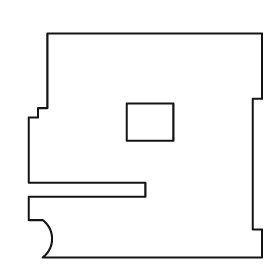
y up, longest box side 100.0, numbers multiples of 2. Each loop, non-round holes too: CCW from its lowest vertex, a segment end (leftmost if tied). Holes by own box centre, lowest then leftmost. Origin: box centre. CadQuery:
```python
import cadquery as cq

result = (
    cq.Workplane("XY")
    .moveTo(-44.0, -48.0)
    .lineTo(50.0, -48.0)
    .lineTo(50.0, -36.0)
    .lineTo(46.0, -36.0)
    .lineTo(46.0, 20.0)
    .lineTo(50.0, 20.0)
    .lineTo(50.0, 48.0)
    .lineTo(-42.0, 48.0)
    .lineTo(-42.0, 16.0)
    .lineTo(-46.0, 16.0)
    .lineTo(-46.0, 12.0)
    .lineTo(-50.0, 12.0)
    .lineTo(-50.0, -16.0)
    .lineTo(0.0, -16.0)
    .lineTo(0.0, -22.0)
    .lineTo(-50.0, -22.0)
    .lineTo(-50.0, -32.0)
    .lineTo(-44.0, -32.0)
    .threePointArc((-40.0, -40.0), (-44.0, -48.0))
    .close()
    .moveTo(-8.0, 2.0)
    .lineTo(12.0, 2.0)
    .lineTo(12.0, 18.0)
    .lineTo(-8.0, 18.0)
    .close()
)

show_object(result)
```